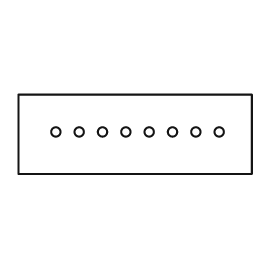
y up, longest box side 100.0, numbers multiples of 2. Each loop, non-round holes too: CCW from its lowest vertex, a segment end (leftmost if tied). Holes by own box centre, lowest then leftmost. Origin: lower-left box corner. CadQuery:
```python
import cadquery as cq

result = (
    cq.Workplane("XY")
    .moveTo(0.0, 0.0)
    .lineTo(100.0, 0.0)
    .lineTo(100.0, 34.0)
    .lineTo(0.0, 34.0)
    .close()
    .moveTo(16.0, 18.0)
    .circle(2.0)
    .moveTo(26.0, 18.0)
    .circle(2.0)
    .moveTo(36.0, 18.0)
    .circle(2.0)
    .moveTo(46.0, 18.0)
    .circle(2.0)
    .moveTo(56.0, 18.0)
    .circle(2.0)
    .moveTo(66.0, 18.0)
    .circle(2.0)
    .moveTo(76.0, 18.0)
    .circle(2.0)
    .moveTo(86.0, 18.0)
    .circle(2.0)
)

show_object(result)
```